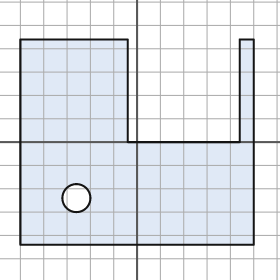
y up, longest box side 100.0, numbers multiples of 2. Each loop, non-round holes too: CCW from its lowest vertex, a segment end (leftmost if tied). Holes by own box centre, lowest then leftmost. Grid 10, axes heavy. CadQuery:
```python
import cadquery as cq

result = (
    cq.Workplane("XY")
    .moveTo(-50.0, -44.0)
    .lineTo(50.0, -44.0)
    .lineTo(50.0, 44.0)
    .lineTo(44.0, 44.0)
    .lineTo(44.0, 0.0)
    .lineTo(-4.0, 0.0)
    .lineTo(-4.0, 44.0)
    .lineTo(-50.0, 44.0)
    .close()
    .moveTo(-26.0, -24.0)
    .circle(6.0)
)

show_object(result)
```